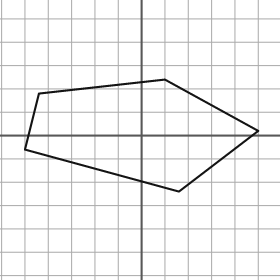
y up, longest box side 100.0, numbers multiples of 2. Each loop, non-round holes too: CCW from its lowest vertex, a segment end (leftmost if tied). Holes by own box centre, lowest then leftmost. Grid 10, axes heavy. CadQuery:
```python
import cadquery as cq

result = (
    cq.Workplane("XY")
    .moveTo(16.0, -24.0)
    .lineTo(50.0, 2.0)
    .lineTo(10.0, 24.0)
    .lineTo(-44.0, 18.0)
    .lineTo(-50.0, -6.0)
    .close()
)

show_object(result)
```